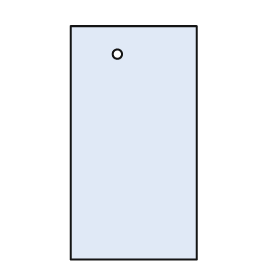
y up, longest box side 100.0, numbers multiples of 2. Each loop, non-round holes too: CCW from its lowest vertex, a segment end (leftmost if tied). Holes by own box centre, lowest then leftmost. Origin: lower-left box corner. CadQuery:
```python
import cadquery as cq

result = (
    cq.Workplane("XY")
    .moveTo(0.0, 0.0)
    .lineTo(54.0, 0.0)
    .lineTo(54.0, 100.0)
    .lineTo(0.0, 100.0)
    .close()
    .moveTo(20.0, 88.0)
    .circle(2.0)
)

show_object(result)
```